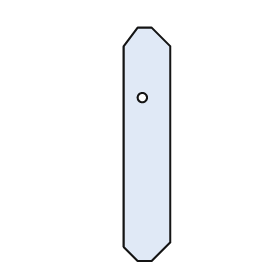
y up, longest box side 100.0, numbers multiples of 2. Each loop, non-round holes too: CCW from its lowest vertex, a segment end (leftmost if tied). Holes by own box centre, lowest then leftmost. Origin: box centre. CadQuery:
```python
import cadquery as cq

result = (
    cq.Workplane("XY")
    .moveTo(-4.0, -50.0)
    .lineTo(2.0, -50.0)
    .lineTo(10.0, -42.0)
    .lineTo(10.0, 42.0)
    .lineTo(2.0, 50.0)
    .lineTo(-4.0, 50.0)
    .lineTo(-10.0, 42.0)
    .lineTo(-10.0, -44.0)
    .close()
    .moveTo(-2.0, 20.0)
    .circle(2.0)
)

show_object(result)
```